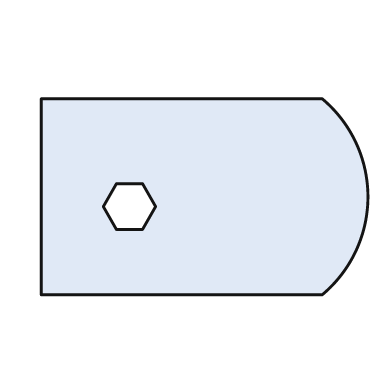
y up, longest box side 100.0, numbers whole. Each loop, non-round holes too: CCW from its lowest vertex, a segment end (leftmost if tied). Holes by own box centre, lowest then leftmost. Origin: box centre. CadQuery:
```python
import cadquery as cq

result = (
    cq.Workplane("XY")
    .moveTo(-50.0, -30.0)
    .lineTo(36.0, -30.0)
    .threePointArc((50.0, 0.0), (36.0, 30.0))
    .lineTo(-50.0, 30.0)
    .close()
    .moveTo(-27.0, -10.0)
    .lineTo(-19.0, -10.0)
    .lineTo(-15.0, -3.0)
    .lineTo(-19.0, 4.0)
    .lineTo(-27.0, 4.0)
    .lineTo(-31.0, -3.0)
    .close()
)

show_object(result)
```